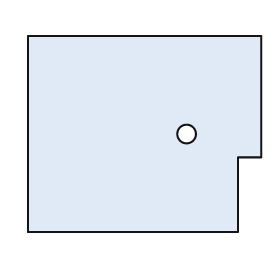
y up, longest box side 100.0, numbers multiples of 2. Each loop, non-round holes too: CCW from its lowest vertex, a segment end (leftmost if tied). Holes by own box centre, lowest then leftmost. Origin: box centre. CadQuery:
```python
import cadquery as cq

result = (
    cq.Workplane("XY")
    .moveTo(-50.0, -42.0)
    .lineTo(40.0, -42.0)
    .lineTo(40.0, -10.0)
    .lineTo(50.0, -10.0)
    .lineTo(50.0, 42.0)
    .lineTo(-50.0, 42.0)
    .close()
    .moveTo(18.0, 0.0)
    .circle(4.0)
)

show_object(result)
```